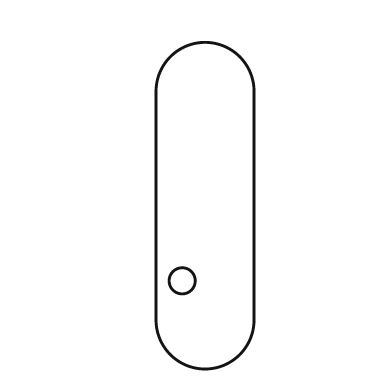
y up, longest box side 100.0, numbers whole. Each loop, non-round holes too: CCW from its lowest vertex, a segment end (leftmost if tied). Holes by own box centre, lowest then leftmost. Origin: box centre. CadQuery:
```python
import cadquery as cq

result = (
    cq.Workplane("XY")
    .moveTo(-15.0, -35.0)
    .threePointArc((0.0, -50.0), (15.0, -35.0))
    .lineTo(15.0, 35.0)
    .threePointArc((0.0, 50.0), (-15.0, 35.0))
    .close()
    .moveTo(-7.0, -23.0)
    .circle(4.0)
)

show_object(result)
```